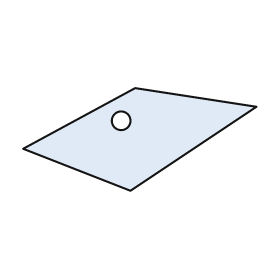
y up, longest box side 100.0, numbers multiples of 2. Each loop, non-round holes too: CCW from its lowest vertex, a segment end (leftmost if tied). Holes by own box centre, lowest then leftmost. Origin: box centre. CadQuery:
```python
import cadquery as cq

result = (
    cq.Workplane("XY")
    .moveTo(-4.0, -22.0)
    .lineTo(50.0, 14.0)
    .lineTo(-2.0, 22.0)
    .lineTo(-50.0, -4.0)
    .close()
    .moveTo(-8.0, 8.0)
    .circle(4.0)
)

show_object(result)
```